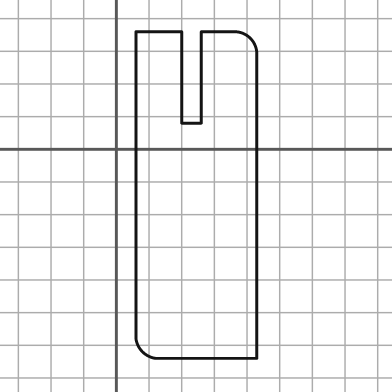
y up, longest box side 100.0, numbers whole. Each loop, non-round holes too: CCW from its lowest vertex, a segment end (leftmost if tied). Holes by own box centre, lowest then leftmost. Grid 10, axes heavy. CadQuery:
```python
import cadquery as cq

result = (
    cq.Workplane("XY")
    .moveTo(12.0, -64.0)
    .lineTo(43.0, -64.0)
    .lineTo(43.0, 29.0)
    .threePointArc((41.0, 34.0), (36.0, 36.0))
    .lineTo(26.0, 36.0)
    .lineTo(26.0, 8.0)
    .lineTo(20.0, 8.0)
    .lineTo(20.0, 36.0)
    .lineTo(6.0, 36.0)
    .lineTo(6.0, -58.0)
    .threePointArc((8.0, -62.0), (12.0, -64.0))
    .close()
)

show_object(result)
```